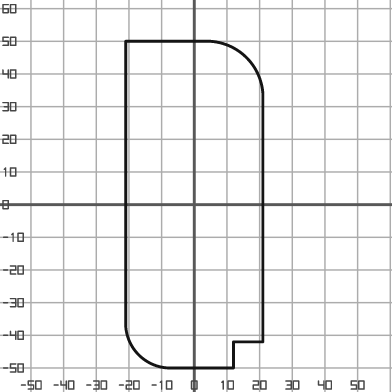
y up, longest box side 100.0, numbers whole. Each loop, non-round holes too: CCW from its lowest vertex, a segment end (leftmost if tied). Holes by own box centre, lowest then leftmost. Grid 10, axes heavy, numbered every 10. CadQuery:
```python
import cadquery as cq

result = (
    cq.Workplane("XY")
    .moveTo(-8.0, -50.0)
    .lineTo(12.0, -50.0)
    .lineTo(12.0, -42.0)
    .lineTo(21.0, -42.0)
    .lineTo(21.0, 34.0)
    .threePointArc((16.0, 45.0), (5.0, 50.0))
    .lineTo(-21.0, 50.0)
    .lineTo(-21.0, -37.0)
    .threePointArc((-17.0, -46.0), (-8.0, -50.0))
    .close()
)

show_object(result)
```